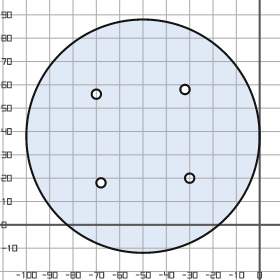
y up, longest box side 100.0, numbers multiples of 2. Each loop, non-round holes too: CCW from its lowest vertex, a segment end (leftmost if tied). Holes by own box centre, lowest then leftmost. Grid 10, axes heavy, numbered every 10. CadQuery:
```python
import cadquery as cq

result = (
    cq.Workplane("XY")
    .moveTo(-50.0, 38.0)
    .circle(50.0)
    .moveTo(-68.0, 18.0)
    .circle(2.0)
    .moveTo(-30.0, 20.0)
    .circle(2.0)
    .moveTo(-70.0, 56.0)
    .circle(2.0)
    .moveTo(-32.0, 58.0)
    .circle(2.0)
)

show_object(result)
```